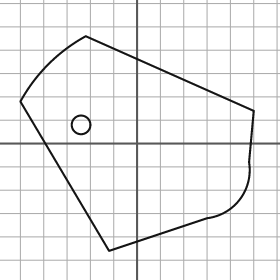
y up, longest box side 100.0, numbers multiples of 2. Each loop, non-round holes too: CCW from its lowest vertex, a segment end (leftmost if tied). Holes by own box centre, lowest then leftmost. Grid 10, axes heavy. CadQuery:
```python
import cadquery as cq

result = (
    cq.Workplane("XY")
    .moveTo(-12.0, -46.0)
    .lineTo(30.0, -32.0)
    .threePointArc((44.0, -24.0), (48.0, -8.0))
    .lineTo(50.0, 14.0)
    .lineTo(-22.0, 46.0)
    .threePointArc((-38.0, 34.0), (-50.0, 18.0))
    .close()
    .moveTo(-24.0, 8.0)
    .circle(4.0)
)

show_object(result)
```